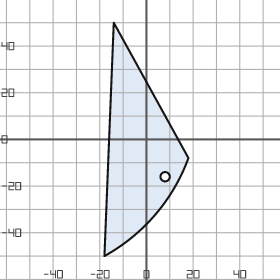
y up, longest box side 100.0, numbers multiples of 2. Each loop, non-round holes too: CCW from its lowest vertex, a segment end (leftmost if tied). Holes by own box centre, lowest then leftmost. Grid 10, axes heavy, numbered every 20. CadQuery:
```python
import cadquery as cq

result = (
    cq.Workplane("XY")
    .moveTo(-18.0, -50.0)
    .threePointArc((4.0, -32.0), (18.0, -8.0))
    .lineTo(-14.0, 50.0)
    .close()
    .moveTo(8.0, -16.0)
    .circle(2.0)
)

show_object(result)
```